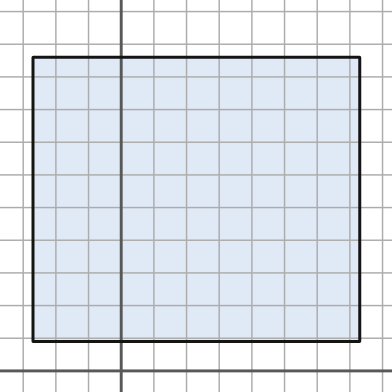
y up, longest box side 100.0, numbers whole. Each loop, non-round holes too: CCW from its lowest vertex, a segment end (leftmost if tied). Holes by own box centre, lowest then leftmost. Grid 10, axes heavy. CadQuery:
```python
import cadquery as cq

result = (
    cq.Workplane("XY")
    .moveTo(-27.0, 9.0)
    .lineTo(73.0, 9.0)
    .lineTo(73.0, 96.0)
    .lineTo(-27.0, 96.0)
    .close()
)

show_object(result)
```